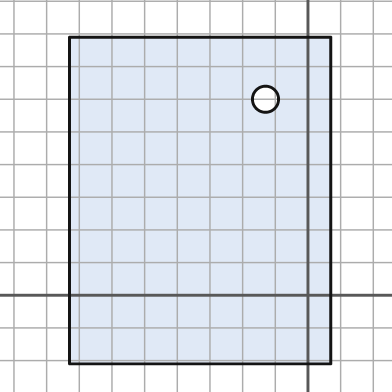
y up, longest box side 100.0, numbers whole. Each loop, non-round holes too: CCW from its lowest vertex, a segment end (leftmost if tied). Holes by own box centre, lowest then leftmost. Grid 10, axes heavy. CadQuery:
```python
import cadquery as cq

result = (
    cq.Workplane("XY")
    .moveTo(-73.0, -21.0)
    .lineTo(7.0, -21.0)
    .lineTo(7.0, 79.0)
    .lineTo(-73.0, 79.0)
    .close()
    .moveTo(-13.0, 60.0)
    .circle(4.0)
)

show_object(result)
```